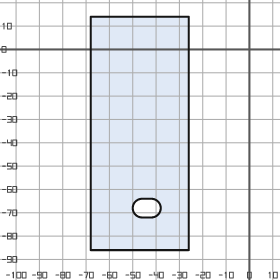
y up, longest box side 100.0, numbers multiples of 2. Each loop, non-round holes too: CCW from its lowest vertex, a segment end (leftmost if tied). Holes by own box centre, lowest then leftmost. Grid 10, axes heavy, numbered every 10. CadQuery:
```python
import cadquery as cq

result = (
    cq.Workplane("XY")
    .moveTo(-68.0, -86.0)
    .lineTo(-26.0, -86.0)
    .lineTo(-26.0, 14.0)
    .lineTo(-68.0, 14.0)
    .close()
    .moveTo(-46.0, -72.0)
    .lineTo(-42.0, -72.0)
    .threePointArc((-38.0, -68.0), (-42.0, -64.0))
    .lineTo(-46.0, -64.0)
    .threePointArc((-50.0, -68.0), (-46.0, -72.0))
    .close()
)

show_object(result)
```